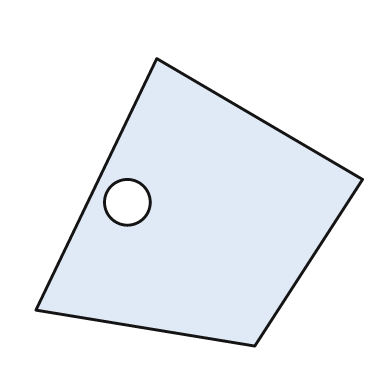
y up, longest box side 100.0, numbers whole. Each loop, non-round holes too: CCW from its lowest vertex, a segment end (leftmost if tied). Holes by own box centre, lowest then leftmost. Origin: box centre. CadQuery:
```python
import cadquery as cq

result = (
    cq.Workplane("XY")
    .moveTo(17.0, -44.0)
    .lineTo(50.0, 7.0)
    .lineTo(-13.0, 44.0)
    .lineTo(-50.0, -33.0)
    .close()
    .moveTo(-22.0, 0.0)
    .circle(7.0)
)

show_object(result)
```